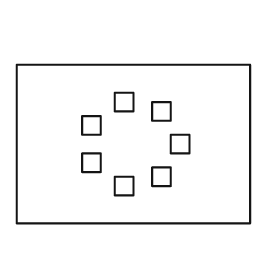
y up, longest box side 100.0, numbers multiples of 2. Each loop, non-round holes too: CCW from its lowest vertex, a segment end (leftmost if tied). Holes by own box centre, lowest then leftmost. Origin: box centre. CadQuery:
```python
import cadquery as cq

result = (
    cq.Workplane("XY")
    .moveTo(-50.0, -34.0)
    .lineTo(50.0, -34.0)
    .lineTo(50.0, 34.0)
    .lineTo(-50.0, 34.0)
    .close()
    .moveTo(-8.0, -22.0)
    .lineTo(0.0, -22.0)
    .lineTo(0.0, -14.0)
    .lineTo(-8.0, -14.0)
    .close()
    .moveTo(8.0, -18.0)
    .lineTo(16.0, -18.0)
    .lineTo(16.0, -10.0)
    .lineTo(8.0, -10.0)
    .close()
    .moveTo(-22.0, -12.0)
    .lineTo(-14.0, -12.0)
    .lineTo(-14.0, -4.0)
    .lineTo(-22.0, -4.0)
    .close()
    .moveTo(16.0, -4.0)
    .lineTo(24.0, -4.0)
    .lineTo(24.0, 4.0)
    .lineTo(16.0, 4.0)
    .close()
    .moveTo(-22.0, 4.0)
    .lineTo(-14.0, 4.0)
    .lineTo(-14.0, 12.0)
    .lineTo(-22.0, 12.0)
    .close()
    .moveTo(8.0, 10.0)
    .lineTo(16.0, 10.0)
    .lineTo(16.0, 18.0)
    .lineTo(8.0, 18.0)
    .close()
    .moveTo(-8.0, 14.0)
    .lineTo(0.0, 14.0)
    .lineTo(0.0, 22.0)
    .lineTo(-8.0, 22.0)
    .close()
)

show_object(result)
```